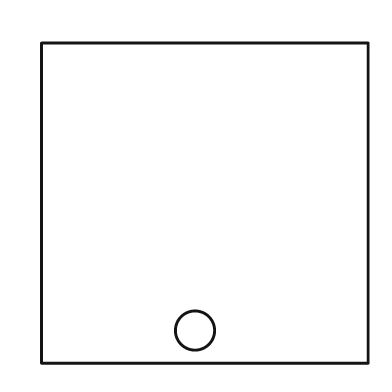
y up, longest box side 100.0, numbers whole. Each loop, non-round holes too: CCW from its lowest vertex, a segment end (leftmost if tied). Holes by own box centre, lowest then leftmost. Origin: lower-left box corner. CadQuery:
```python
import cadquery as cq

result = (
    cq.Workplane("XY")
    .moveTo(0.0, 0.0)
    .lineTo(100.0, 0.0)
    .lineTo(100.0, 98.0)
    .lineTo(0.0, 98.0)
    .close()
    .moveTo(47.0, 10.0)
    .circle(6.0)
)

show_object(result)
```